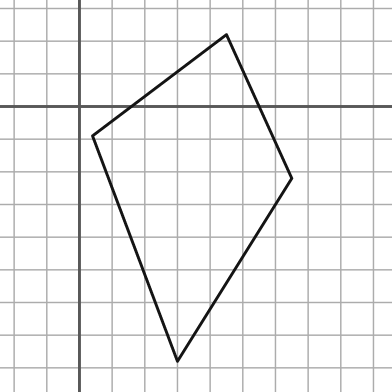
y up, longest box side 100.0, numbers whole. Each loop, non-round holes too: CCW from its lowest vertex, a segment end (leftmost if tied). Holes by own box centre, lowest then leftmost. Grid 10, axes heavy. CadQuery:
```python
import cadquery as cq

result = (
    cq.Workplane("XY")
    .moveTo(30.0, -78.0)
    .lineTo(65.0, -22.0)
    .lineTo(45.0, 22.0)
    .lineTo(4.0, -9.0)
    .close()
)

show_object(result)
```